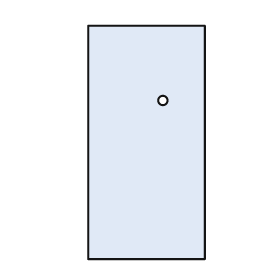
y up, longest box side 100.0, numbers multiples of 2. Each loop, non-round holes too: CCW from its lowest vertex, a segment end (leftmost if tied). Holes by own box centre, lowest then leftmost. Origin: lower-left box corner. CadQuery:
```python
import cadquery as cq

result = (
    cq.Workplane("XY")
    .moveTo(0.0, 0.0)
    .lineTo(50.0, 0.0)
    .lineTo(50.0, 100.0)
    .lineTo(0.0, 100.0)
    .close()
    .moveTo(32.0, 68.0)
    .circle(2.0)
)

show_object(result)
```